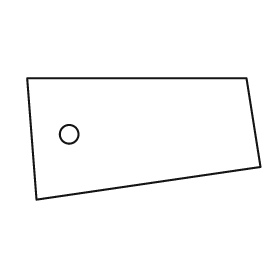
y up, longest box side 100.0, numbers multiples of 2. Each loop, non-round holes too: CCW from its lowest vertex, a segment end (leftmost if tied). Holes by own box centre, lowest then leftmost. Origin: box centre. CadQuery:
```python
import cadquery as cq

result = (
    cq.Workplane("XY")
    .moveTo(-46.0, -26.0)
    .lineTo(50.0, -12.0)
    .lineTo(44.0, 26.0)
    .lineTo(-50.0, 26.0)
    .close()
    .moveTo(-32.0, 2.0)
    .circle(4.0)
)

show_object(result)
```